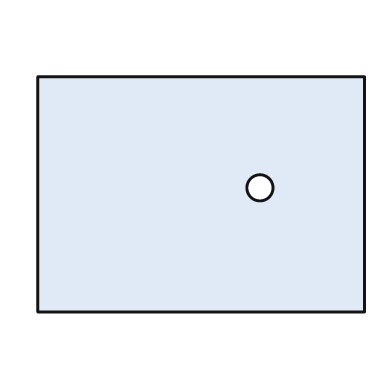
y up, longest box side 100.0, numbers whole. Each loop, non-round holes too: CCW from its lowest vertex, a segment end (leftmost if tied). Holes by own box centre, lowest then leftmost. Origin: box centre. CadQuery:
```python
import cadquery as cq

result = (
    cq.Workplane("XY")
    .moveTo(-50.0, -36.0)
    .lineTo(50.0, -36.0)
    .lineTo(50.0, 36.0)
    .lineTo(-50.0, 36.0)
    .close()
    .moveTo(18.0, 2.0)
    .circle(4.0)
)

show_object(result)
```